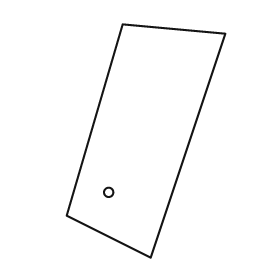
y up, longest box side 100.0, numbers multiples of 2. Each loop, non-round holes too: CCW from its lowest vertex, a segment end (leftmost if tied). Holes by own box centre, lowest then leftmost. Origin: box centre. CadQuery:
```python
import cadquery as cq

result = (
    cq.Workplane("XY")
    .moveTo(2.0, -50.0)
    .lineTo(34.0, 46.0)
    .lineTo(-10.0, 50.0)
    .lineTo(-34.0, -32.0)
    .close()
    .moveTo(-16.0, -22.0)
    .circle(2.0)
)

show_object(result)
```